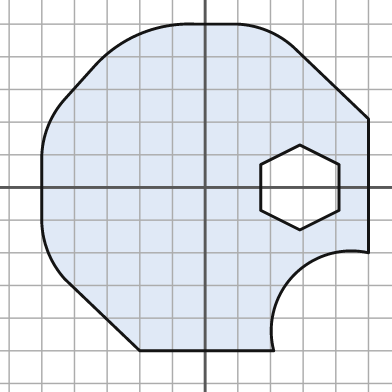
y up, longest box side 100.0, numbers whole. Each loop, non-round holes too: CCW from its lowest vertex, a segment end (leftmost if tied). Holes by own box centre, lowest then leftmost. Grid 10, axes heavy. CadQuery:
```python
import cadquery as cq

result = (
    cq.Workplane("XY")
    .moveTo(-20.0, -50.0)
    .lineTo(21.0, -50.0)
    .threePointArc((27.0, -27.0), (50.0, -20.0))
    .lineTo(50.0, 21.0)
    .lineTo(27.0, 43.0)
    .threePointArc((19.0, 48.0), (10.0, 50.0))
    .lineTo(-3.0, 50.0)
    .threePointArc((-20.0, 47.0), (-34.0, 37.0))
    .lineTo(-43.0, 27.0)
    .threePointArc((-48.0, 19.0), (-50.0, 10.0))
    .lineTo(-50.0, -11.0)
    .threePointArc((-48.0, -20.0), (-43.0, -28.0))
    .close()
    .moveTo(29.0, -13.0)
    .lineTo(41.0, -7.0)
    .lineTo(41.0, 7.0)
    .lineTo(29.0, 13.0)
    .lineTo(17.0, 7.0)
    .lineTo(17.0, -7.0)
    .close()
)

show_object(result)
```